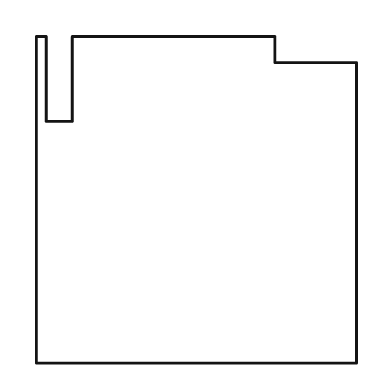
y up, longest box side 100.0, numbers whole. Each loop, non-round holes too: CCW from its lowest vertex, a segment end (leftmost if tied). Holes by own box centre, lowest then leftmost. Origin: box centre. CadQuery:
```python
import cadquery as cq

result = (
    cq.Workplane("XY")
    .moveTo(-49.0, -50.0)
    .lineTo(49.0, -50.0)
    .lineTo(49.0, 42.0)
    .lineTo(24.0, 42.0)
    .lineTo(24.0, 50.0)
    .lineTo(-38.0, 50.0)
    .lineTo(-38.0, 24.0)
    .lineTo(-46.0, 24.0)
    .lineTo(-46.0, 50.0)
    .lineTo(-49.0, 50.0)
    .close()
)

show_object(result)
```